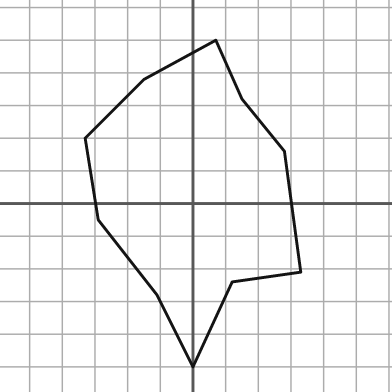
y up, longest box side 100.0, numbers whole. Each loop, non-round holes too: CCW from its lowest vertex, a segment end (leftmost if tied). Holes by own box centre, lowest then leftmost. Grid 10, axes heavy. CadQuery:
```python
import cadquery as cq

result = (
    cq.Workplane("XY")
    .moveTo(0.0, -50.0)
    .lineTo(12.0, -24.0)
    .lineTo(33.0, -21.0)
    .lineTo(28.0, 16.0)
    .lineTo(15.0, 32.0)
    .lineTo(7.0, 50.0)
    .lineTo(-15.0, 38.0)
    .lineTo(-33.0, 20.0)
    .lineTo(-29.0, -5.0)
    .lineTo(-11.0, -28.0)
    .close()
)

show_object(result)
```